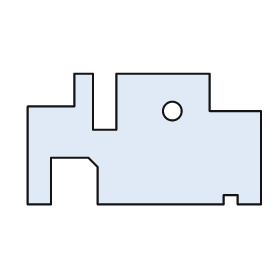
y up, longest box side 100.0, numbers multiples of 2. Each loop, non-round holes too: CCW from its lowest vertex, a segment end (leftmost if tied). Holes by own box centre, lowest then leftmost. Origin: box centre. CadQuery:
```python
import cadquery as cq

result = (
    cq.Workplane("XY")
    .moveTo(-50.0, -28.0)
    .lineTo(-40.0, -28.0)
    .lineTo(-40.0, -8.0)
    .lineTo(-24.0, -8.0)
    .lineTo(-20.0, -12.0)
    .lineTo(-20.0, -28.0)
    .lineTo(34.0, -28.0)
    .lineTo(34.0, -24.0)
    .lineTo(40.0, -24.0)
    .lineTo(40.0, -28.0)
    .lineTo(50.0, -28.0)
    .lineTo(50.0, 12.0)
    .lineTo(28.0, 12.0)
    .lineTo(28.0, 28.0)
    .lineTo(-12.0, 28.0)
    .lineTo(-12.0, 4.0)
    .lineTo(-22.0, 4.0)
    .lineTo(-22.0, 28.0)
    .lineTo(-30.0, 28.0)
    .lineTo(-30.0, 14.0)
    .lineTo(-50.0, 14.0)
    .close()
    .moveTo(12.0, 12.0)
    .circle(4.0)
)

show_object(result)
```